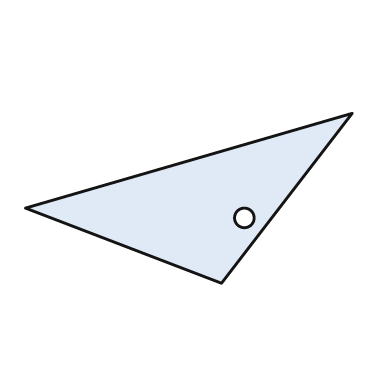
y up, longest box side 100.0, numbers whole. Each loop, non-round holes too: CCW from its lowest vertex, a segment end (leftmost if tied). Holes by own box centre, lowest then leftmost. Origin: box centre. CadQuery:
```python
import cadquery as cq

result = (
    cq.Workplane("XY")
    .moveTo(10.0, -26.0)
    .lineTo(50.0, 26.0)
    .lineTo(-50.0, -3.0)
    .close()
    .moveTo(17.0, -6.0)
    .circle(3.0)
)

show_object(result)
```